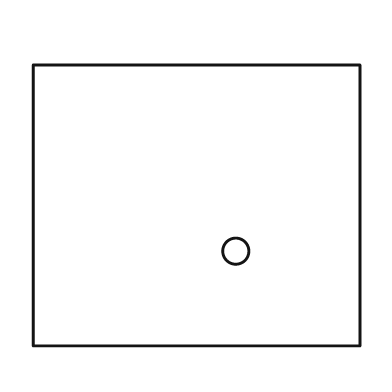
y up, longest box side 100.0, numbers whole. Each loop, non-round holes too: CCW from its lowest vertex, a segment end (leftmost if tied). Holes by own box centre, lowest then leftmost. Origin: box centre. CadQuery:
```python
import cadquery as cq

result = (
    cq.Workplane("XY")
    .moveTo(-50.0, -43.0)
    .lineTo(50.0, -43.0)
    .lineTo(50.0, 43.0)
    .lineTo(-50.0, 43.0)
    .close()
    .moveTo(12.0, -14.0)
    .circle(4.0)
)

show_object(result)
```